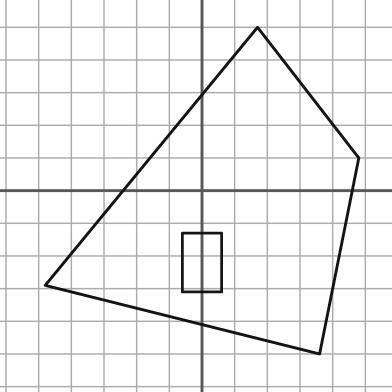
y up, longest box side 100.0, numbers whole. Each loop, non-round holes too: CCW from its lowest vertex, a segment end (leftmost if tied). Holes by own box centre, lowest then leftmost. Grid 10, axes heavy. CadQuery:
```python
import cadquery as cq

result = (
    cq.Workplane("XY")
    .moveTo(36.0, -50.0)
    .lineTo(48.0, 10.0)
    .lineTo(17.0, 50.0)
    .lineTo(-48.0, -29.0)
    .close()
    .moveTo(-6.0, -31.0)
    .lineTo(6.0, -31.0)
    .lineTo(6.0, -13.0)
    .lineTo(-6.0, -13.0)
    .close()
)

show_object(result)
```